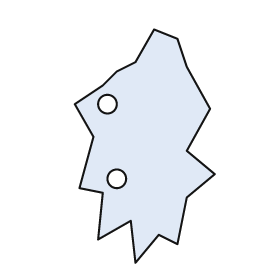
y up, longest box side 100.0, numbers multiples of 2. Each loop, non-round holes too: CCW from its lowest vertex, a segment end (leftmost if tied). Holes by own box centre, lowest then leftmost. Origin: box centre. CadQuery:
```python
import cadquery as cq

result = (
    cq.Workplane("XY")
    .moveTo(-4.0, -50.0)
    .lineTo(6.0, -38.0)
    .lineTo(14.0, -42.0)
    .lineTo(18.0, -22.0)
    .lineTo(30.0, -12.0)
    .lineTo(18.0, -2.0)
    .lineTo(28.0, 16.0)
    .lineTo(18.0, 34.0)
    .lineTo(14.0, 46.0)
    .lineTo(4.0, 50.0)
    .lineTo(-4.0, 36.0)
    .lineTo(-12.0, 32.0)
    .lineTo(-18.0, 26.0)
    .lineTo(-30.0, 18.0)
    .lineTo(-22.0, 4.0)
    .lineTo(-28.0, -18.0)
    .lineTo(-18.0, -20.0)
    .lineTo(-20.0, -40.0)
    .lineTo(-6.0, -32.0)
    .close()
    .moveTo(-12.0, -14.0)
    .circle(4.0)
    .moveTo(-16.0, 18.0)
    .circle(4.0)
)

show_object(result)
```